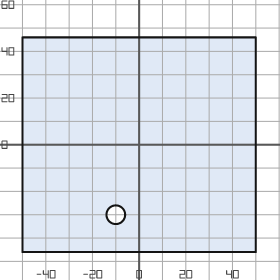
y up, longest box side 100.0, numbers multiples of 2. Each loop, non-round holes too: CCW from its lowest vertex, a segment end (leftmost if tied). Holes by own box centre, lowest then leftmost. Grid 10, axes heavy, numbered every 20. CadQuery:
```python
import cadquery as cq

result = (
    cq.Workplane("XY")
    .moveTo(-50.0, -46.0)
    .lineTo(50.0, -46.0)
    .lineTo(50.0, 46.0)
    .lineTo(-50.0, 46.0)
    .close()
    .moveTo(-10.0, -30.0)
    .circle(4.0)
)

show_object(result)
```